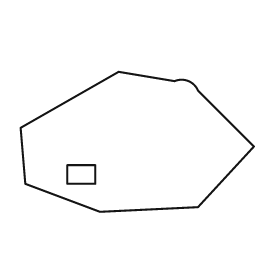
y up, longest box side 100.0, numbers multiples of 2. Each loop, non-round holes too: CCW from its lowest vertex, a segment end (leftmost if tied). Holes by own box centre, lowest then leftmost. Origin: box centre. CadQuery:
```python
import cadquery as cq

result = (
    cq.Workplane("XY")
    .moveTo(-16.0, -30.0)
    .lineTo(26.0, -28.0)
    .lineTo(50.0, -2.0)
    .lineTo(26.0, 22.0)
    .threePointArc((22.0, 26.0), (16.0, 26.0))
    .lineTo(-8.0, 30.0)
    .lineTo(-50.0, 6.0)
    .lineTo(-48.0, -18.0)
    .close()
    .moveTo(-30.0, -18.0)
    .lineTo(-18.0, -18.0)
    .lineTo(-18.0, -10.0)
    .lineTo(-30.0, -10.0)
    .close()
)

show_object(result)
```